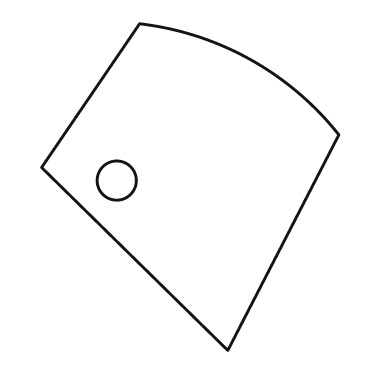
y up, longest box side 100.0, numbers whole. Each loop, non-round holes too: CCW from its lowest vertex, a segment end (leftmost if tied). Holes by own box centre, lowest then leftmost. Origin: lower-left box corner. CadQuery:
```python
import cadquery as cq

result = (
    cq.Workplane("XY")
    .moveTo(57.0, 0.0)
    .lineTo(91.0, 66.0)
    .threePointArc((64.0, 89.0), (30.0, 100.0))
    .lineTo(0.0, 56.0)
    .close()
    .moveTo(23.0, 52.0)
    .circle(6.0)
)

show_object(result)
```